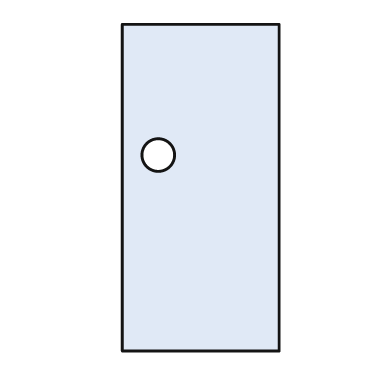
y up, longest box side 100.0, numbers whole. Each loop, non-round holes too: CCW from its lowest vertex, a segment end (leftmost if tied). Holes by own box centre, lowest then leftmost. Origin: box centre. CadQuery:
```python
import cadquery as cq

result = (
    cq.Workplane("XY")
    .moveTo(-24.0, -50.0)
    .lineTo(24.0, -50.0)
    .lineTo(24.0, 50.0)
    .lineTo(-24.0, 50.0)
    .close()
    .moveTo(-13.0, 10.0)
    .circle(5.0)
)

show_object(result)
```